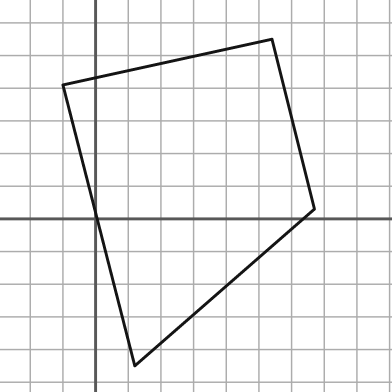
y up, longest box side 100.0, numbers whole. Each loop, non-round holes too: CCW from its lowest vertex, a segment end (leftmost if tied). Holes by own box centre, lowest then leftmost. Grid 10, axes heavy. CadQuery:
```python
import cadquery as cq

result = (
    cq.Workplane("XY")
    .moveTo(12.0, -45.0)
    .lineTo(67.0, 3.0)
    .lineTo(54.0, 55.0)
    .lineTo(-10.0, 41.0)
    .close()
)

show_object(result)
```